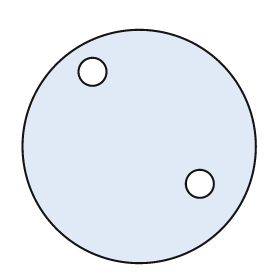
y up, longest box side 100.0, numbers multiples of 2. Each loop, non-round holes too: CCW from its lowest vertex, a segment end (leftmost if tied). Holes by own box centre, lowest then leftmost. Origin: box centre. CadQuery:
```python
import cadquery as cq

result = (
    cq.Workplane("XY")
    .moveTo(0.0, 0.0)
    .circle(50.0)
    .moveTo(26.0, -16.0)
    .circle(6.0)
    .moveTo(-20.0, 32.0)
    .circle(6.0)
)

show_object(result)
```